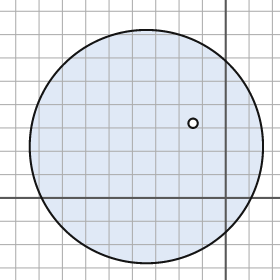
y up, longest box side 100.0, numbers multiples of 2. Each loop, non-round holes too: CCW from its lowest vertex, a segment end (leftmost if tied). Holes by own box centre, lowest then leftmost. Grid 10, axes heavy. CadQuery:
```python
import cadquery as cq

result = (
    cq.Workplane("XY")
    .moveTo(-34.0, 22.0)
    .circle(50.0)
    .moveTo(-14.0, 32.0)
    .circle(2.0)
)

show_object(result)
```